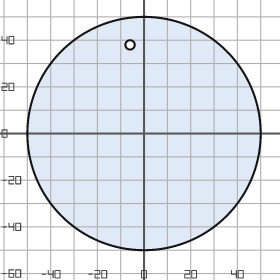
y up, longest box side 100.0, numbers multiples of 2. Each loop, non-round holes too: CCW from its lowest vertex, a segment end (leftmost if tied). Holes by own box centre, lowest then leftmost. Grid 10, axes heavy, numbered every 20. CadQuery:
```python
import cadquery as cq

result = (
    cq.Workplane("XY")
    .moveTo(0.0, 0.0)
    .circle(50.0)
    .moveTo(-6.0, 38.0)
    .circle(2.0)
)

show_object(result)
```